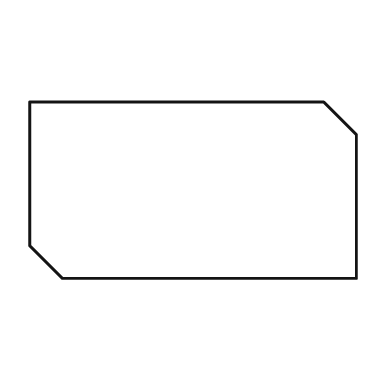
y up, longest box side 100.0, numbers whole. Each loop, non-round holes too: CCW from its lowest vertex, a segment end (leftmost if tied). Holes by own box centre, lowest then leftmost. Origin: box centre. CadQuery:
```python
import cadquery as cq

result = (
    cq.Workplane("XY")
    .moveTo(-40.0, -27.0)
    .lineTo(50.0, -27.0)
    .lineTo(50.0, 17.0)
    .lineTo(40.0, 27.0)
    .lineTo(-50.0, 27.0)
    .lineTo(-50.0, -17.0)
    .close()
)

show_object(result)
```